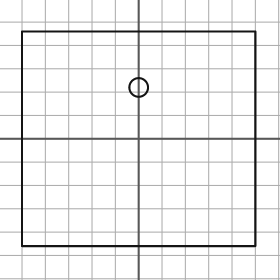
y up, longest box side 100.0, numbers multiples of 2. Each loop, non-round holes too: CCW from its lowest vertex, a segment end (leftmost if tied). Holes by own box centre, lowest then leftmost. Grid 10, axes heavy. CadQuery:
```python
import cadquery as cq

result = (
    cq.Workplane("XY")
    .moveTo(-50.0, -46.0)
    .lineTo(50.0, -46.0)
    .lineTo(50.0, 46.0)
    .lineTo(-50.0, 46.0)
    .close()
    .moveTo(0.0, 22.0)
    .circle(4.0)
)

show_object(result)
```